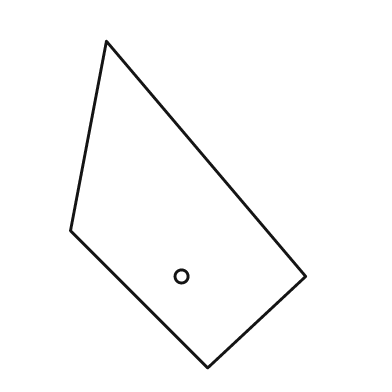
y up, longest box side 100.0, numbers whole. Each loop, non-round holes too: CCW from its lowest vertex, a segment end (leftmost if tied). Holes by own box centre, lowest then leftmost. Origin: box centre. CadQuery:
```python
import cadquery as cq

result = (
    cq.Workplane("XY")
    .moveTo(6.0, -50.0)
    .lineTo(36.0, -22.0)
    .lineTo(-25.0, 50.0)
    .lineTo(-36.0, -8.0)
    .close()
    .moveTo(-2.0, -22.0)
    .circle(2.0)
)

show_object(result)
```